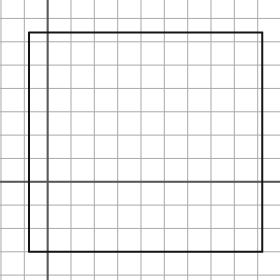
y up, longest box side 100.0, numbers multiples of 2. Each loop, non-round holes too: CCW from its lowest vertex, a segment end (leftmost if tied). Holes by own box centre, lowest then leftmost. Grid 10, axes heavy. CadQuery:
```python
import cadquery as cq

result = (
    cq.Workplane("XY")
    .moveTo(-8.0, -30.0)
    .lineTo(92.0, -30.0)
    .lineTo(92.0, 64.0)
    .lineTo(-8.0, 64.0)
    .close()
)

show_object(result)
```